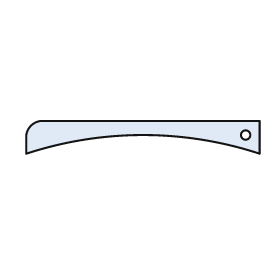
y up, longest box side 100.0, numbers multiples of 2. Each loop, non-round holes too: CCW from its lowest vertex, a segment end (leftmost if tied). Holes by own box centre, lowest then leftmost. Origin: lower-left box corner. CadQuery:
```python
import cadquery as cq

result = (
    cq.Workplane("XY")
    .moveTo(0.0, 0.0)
    .threePointArc((50.0, 8.0), (100.0, 0.0))
    .lineTo(100.0, 14.0)
    .lineTo(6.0, 14.0)
    .threePointArc((2.0, 12.0), (0.0, 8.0))
    .close()
    .moveTo(94.0, 8.0)
    .circle(2.0)
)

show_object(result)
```